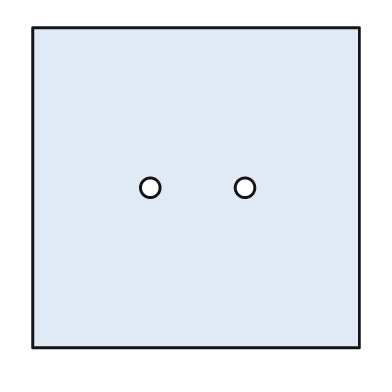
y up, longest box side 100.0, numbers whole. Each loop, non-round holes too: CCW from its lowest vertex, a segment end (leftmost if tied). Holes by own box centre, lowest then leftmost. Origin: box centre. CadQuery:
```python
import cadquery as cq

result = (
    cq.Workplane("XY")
    .moveTo(-50.0, -49.0)
    .lineTo(50.0, -49.0)
    .lineTo(50.0, 49.0)
    .lineTo(-50.0, 49.0)
    .close()
    .moveTo(-14.0, 0.0)
    .circle(3.0)
    .moveTo(15.0, 0.0)
    .circle(3.0)
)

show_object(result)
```